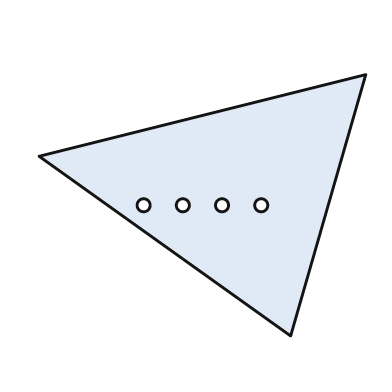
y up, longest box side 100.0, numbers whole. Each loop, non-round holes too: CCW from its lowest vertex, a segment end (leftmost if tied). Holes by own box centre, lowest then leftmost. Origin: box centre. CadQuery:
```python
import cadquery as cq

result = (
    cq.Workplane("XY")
    .moveTo(27.0, -40.0)
    .lineTo(50.0, 40.0)
    .lineTo(-50.0, 15.0)
    .close()
    .moveTo(-18.0, 0.0)
    .circle(2.0)
    .moveTo(-6.0, 0.0)
    .circle(2.0)
    .moveTo(6.0, 0.0)
    .circle(2.0)
    .moveTo(18.0, 0.0)
    .circle(2.0)
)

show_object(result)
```